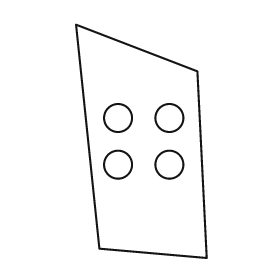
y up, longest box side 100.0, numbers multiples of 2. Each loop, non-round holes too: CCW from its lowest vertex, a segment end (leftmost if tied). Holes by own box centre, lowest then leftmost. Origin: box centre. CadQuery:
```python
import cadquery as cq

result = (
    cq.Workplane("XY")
    .moveTo(28.0, -50.0)
    .lineTo(24.0, 30.0)
    .lineTo(-28.0, 50.0)
    .lineTo(-18.0, -46.0)
    .close()
    .moveTo(-10.0, -10.0)
    .circle(6.0)
    .moveTo(12.0, -10.0)
    .circle(6.0)
    .moveTo(-10.0, 10.0)
    .circle(6.0)
    .moveTo(12.0, 10.0)
    .circle(6.0)
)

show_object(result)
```